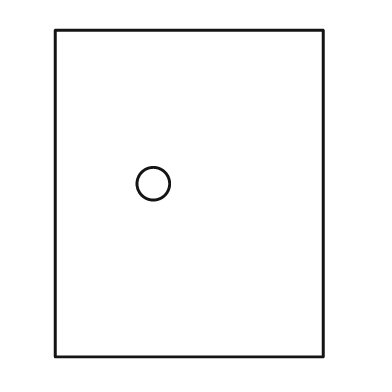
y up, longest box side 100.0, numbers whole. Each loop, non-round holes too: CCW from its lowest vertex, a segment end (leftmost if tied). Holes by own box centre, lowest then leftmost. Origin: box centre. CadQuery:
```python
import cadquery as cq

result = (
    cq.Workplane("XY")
    .moveTo(-41.0, -50.0)
    .lineTo(41.0, -50.0)
    .lineTo(41.0, 50.0)
    .lineTo(-41.0, 50.0)
    .close()
    .moveTo(-11.0, 3.0)
    .circle(5.0)
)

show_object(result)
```